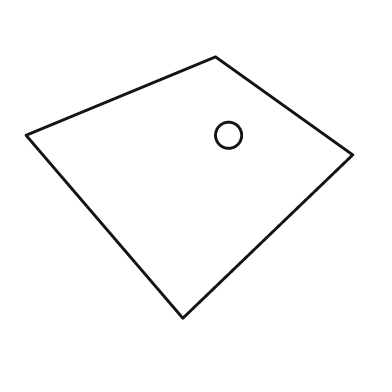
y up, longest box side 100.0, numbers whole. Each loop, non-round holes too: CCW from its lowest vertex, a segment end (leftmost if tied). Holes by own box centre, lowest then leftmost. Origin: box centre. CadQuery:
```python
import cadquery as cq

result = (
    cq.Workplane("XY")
    .moveTo(-2.0, -40.0)
    .lineTo(50.0, 10.0)
    .lineTo(8.0, 40.0)
    .lineTo(-50.0, 16.0)
    .close()
    .moveTo(12.0, 16.0)
    .circle(4.0)
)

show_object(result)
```